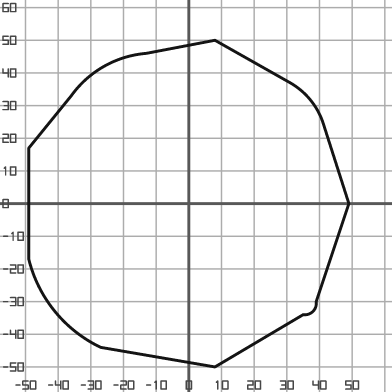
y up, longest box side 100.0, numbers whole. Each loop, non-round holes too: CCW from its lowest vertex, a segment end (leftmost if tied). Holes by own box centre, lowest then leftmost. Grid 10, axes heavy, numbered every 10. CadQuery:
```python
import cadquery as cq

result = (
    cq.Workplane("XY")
    .moveTo(8.0, -50.0)
    .lineTo(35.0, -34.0)
    .threePointArc((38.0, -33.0), (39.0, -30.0))
    .lineTo(49.0, 0.0)
    .lineTo(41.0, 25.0)
    .threePointArc((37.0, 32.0), (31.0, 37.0))
    .lineTo(8.0, 50.0)
    .lineTo(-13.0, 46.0)
    .threePointArc((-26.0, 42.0), (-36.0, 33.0))
    .lineTo(-49.0, 17.0)
    .lineTo(-49.0, -17.0)
    .threePointArc((-41.0, -33.0), (-27.0, -44.0))
    .close()
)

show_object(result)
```